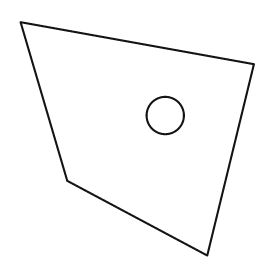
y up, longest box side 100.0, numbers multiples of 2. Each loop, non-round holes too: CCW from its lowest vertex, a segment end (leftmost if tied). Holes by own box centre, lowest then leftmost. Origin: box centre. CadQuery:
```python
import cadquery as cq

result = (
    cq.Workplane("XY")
    .moveTo(30.0, -50.0)
    .lineTo(50.0, 32.0)
    .lineTo(-50.0, 50.0)
    .lineTo(-30.0, -18.0)
    .close()
    .moveTo(12.0, 10.0)
    .circle(8.0)
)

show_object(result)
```